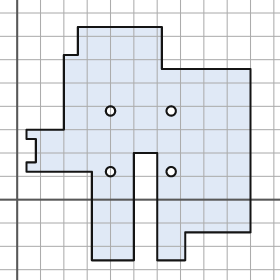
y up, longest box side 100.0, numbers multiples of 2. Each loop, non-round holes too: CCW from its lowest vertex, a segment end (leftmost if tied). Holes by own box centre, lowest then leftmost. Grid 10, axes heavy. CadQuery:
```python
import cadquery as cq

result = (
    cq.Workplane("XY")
    .moveTo(32.0, -26.0)
    .lineTo(50.0, -26.0)
    .lineTo(50.0, 20.0)
    .lineTo(60.0, 20.0)
    .lineTo(60.0, -26.0)
    .lineTo(72.0, -26.0)
    .lineTo(72.0, -14.0)
    .lineTo(100.0, -14.0)
    .lineTo(100.0, 56.0)
    .lineTo(62.0, 56.0)
    .lineTo(62.0, 74.0)
    .lineTo(26.0, 74.0)
    .lineTo(26.0, 62.0)
    .lineTo(20.0, 62.0)
    .lineTo(20.0, 30.0)
    .lineTo(4.0, 30.0)
    .lineTo(4.0, 26.0)
    .lineTo(8.0, 26.0)
    .lineTo(8.0, 16.0)
    .lineTo(4.0, 16.0)
    .lineTo(4.0, 12.0)
    .lineTo(32.0, 12.0)
    .close()
    .moveTo(40.0, 12.0)
    .circle(2.0)
    .moveTo(66.0, 12.0)
    .circle(2.0)
    .moveTo(40.0, 38.0)
    .circle(2.0)
    .moveTo(66.0, 38.0)
    .circle(2.0)
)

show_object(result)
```